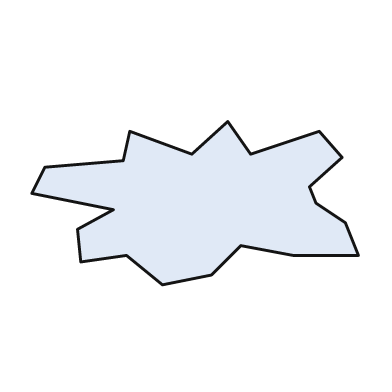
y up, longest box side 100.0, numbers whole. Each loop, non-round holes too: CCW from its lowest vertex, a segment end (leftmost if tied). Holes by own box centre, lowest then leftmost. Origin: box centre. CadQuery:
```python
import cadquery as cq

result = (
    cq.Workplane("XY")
    .moveTo(-10.0, -25.0)
    .lineTo(5.0, -22.0)
    .lineTo(14.0, -13.0)
    .lineTo(30.0, -16.0)
    .lineTo(50.0, -16.0)
    .lineTo(46.0, -6.0)
    .lineTo(37.0, 0.0)
    .lineTo(35.0, 5.0)
    .lineTo(45.0, 14.0)
    .lineTo(38.0, 22.0)
    .lineTo(17.0, 15.0)
    .lineTo(10.0, 25.0)
    .lineTo(-1.0, 15.0)
    .lineTo(-20.0, 22.0)
    .lineTo(-22.0, 13.0)
    .lineTo(-46.0, 11.0)
    .lineTo(-50.0, 3.0)
    .lineTo(-25.0, -2.0)
    .lineTo(-36.0, -8.0)
    .lineTo(-35.0, -18.0)
    .lineTo(-21.0, -16.0)
    .close()
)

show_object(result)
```